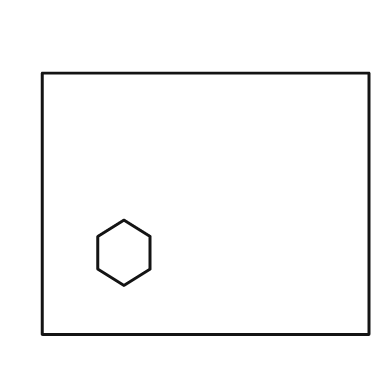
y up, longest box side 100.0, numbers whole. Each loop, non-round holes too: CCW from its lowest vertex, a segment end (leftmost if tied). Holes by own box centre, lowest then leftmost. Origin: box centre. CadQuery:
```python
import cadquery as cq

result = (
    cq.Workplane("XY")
    .moveTo(-50.0, -40.0)
    .lineTo(50.0, -40.0)
    .lineTo(50.0, 40.0)
    .lineTo(-50.0, 40.0)
    .close()
    .moveTo(-25.0, -25.0)
    .lineTo(-17.0, -20.0)
    .lineTo(-17.0, -10.0)
    .lineTo(-25.0, -5.0)
    .lineTo(-33.0, -10.0)
    .lineTo(-33.0, -20.0)
    .close()
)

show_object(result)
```